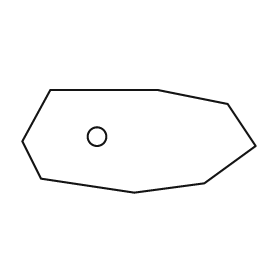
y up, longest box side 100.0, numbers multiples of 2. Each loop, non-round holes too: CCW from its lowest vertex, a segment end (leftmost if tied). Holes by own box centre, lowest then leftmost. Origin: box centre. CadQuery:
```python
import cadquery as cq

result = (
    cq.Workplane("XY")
    .moveTo(-2.0, -22.0)
    .lineTo(28.0, -18.0)
    .lineTo(50.0, -2.0)
    .lineTo(38.0, 16.0)
    .lineTo(8.0, 22.0)
    .lineTo(-38.0, 22.0)
    .lineTo(-50.0, 0.0)
    .lineTo(-42.0, -16.0)
    .close()
    .moveTo(-18.0, 2.0)
    .circle(4.0)
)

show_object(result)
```